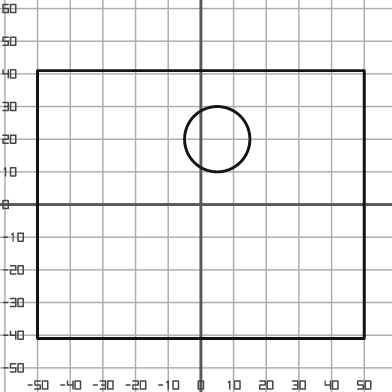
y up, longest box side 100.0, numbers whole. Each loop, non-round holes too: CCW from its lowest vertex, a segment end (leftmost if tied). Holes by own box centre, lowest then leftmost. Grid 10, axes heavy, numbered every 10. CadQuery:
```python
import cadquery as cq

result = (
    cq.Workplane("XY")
    .moveTo(-50.0, -41.0)
    .lineTo(50.0, -41.0)
    .lineTo(50.0, 41.0)
    .lineTo(-50.0, 41.0)
    .close()
    .moveTo(5.0, 20.0)
    .circle(10.0)
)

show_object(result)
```